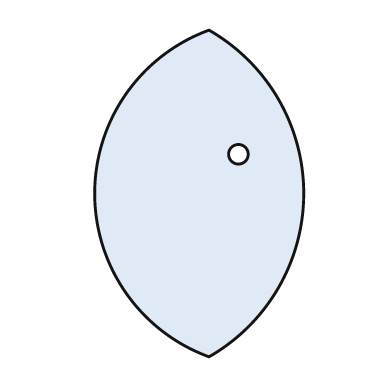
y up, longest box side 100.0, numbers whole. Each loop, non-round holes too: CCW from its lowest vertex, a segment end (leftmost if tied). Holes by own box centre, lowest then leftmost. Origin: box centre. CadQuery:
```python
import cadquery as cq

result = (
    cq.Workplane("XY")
    .moveTo(3.0, -50.0)
    .threePointArc((32.0, 0.0), (3.0, 50.0))
    .threePointArc((-32.0, 0.0), (3.0, -50.0))
    .close()
    .moveTo(12.0, 12.0)
    .circle(3.0)
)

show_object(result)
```